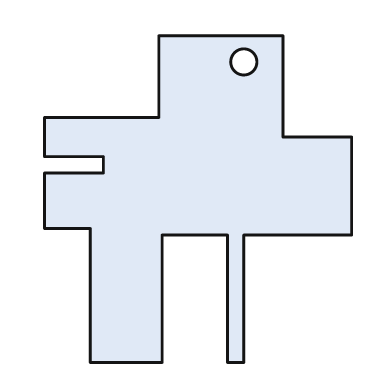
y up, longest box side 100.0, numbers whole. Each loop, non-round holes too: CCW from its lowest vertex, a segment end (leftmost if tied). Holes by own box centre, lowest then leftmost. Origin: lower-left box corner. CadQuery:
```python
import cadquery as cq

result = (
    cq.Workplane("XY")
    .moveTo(14.0, 0.0)
    .lineTo(36.0, 0.0)
    .lineTo(36.0, 39.0)
    .lineTo(56.0, 39.0)
    .lineTo(56.0, 0.0)
    .lineTo(61.0, 0.0)
    .lineTo(61.0, 39.0)
    .lineTo(94.0, 39.0)
    .lineTo(94.0, 69.0)
    .lineTo(73.0, 69.0)
    .lineTo(73.0, 100.0)
    .lineTo(35.0, 100.0)
    .lineTo(35.0, 75.0)
    .lineTo(0.0, 75.0)
    .lineTo(0.0, 63.0)
    .lineTo(18.0, 63.0)
    .lineTo(18.0, 58.0)
    .lineTo(0.0, 58.0)
    .lineTo(0.0, 41.0)
    .lineTo(14.0, 41.0)
    .close()
    .moveTo(61.0, 92.0)
    .circle(4.0)
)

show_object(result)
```